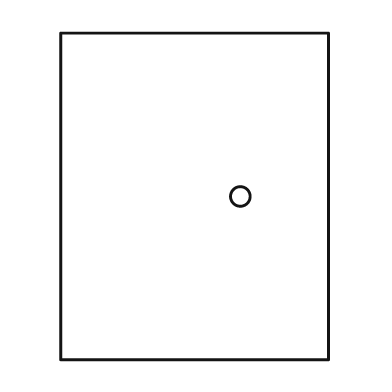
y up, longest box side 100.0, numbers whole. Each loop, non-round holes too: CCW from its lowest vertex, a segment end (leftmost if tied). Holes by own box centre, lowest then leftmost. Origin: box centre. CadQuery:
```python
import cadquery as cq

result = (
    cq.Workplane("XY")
    .moveTo(-41.0, -50.0)
    .lineTo(41.0, -50.0)
    .lineTo(41.0, 50.0)
    .lineTo(-41.0, 50.0)
    .close()
    .moveTo(14.0, 0.0)
    .circle(3.0)
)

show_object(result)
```